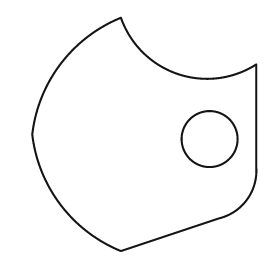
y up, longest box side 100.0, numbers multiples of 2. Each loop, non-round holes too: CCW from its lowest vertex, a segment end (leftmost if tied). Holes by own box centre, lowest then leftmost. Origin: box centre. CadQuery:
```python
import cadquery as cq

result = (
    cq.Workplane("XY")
    .moveTo(-10.0, -50.0)
    .lineTo(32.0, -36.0)
    .threePointArc((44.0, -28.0), (48.0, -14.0))
    .lineTo(48.0, 30.0)
    .threePointArc((14.0, 26.0), (-10.0, 50.0))
    .threePointArc((-36.0, 30.0), (-48.0, 0.0))
    .threePointArc((-36.0, -30.0), (-10.0, -50.0))
    .close()
    .moveTo(28.0, -2.0)
    .circle(12.0)
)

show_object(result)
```